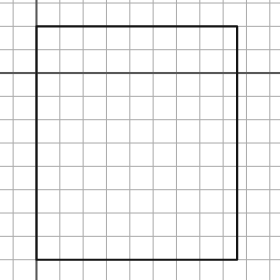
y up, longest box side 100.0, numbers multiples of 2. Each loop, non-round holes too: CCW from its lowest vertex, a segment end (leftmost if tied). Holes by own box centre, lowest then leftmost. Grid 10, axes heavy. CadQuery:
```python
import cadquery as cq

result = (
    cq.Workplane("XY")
    .moveTo(0.0, -80.0)
    .lineTo(86.0, -80.0)
    .lineTo(86.0, 20.0)
    .lineTo(0.0, 20.0)
    .close()
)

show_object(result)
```